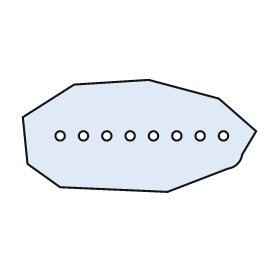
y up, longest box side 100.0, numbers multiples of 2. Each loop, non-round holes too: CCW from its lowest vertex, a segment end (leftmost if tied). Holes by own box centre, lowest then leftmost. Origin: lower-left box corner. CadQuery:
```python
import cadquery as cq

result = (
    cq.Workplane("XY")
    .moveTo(62.0, 0.0)
    .lineTo(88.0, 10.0)
    .threePointArc((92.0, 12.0), (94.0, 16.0))
    .lineTo(100.0, 26.0)
    .lineTo(84.0, 40.0)
    .lineTo(54.0, 48.0)
    .lineTo(22.0, 46.0)
    .lineTo(0.0, 32.0)
    .lineTo(2.0, 12.0)
    .lineTo(16.0, 2.0)
    .close()
    .moveTo(16.0, 24.0)
    .circle(2.0)
    .moveTo(26.0, 24.0)
    .circle(2.0)
    .moveTo(36.0, 24.0)
    .circle(2.0)
    .moveTo(46.0, 24.0)
    .circle(2.0)
    .moveTo(56.0, 24.0)
    .circle(2.0)
    .moveTo(66.0, 24.0)
    .circle(2.0)
    .moveTo(76.0, 24.0)
    .circle(2.0)
    .moveTo(86.0, 24.0)
    .circle(2.0)
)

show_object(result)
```